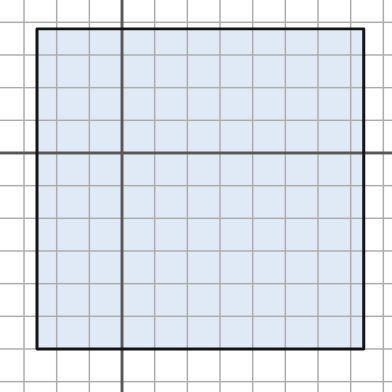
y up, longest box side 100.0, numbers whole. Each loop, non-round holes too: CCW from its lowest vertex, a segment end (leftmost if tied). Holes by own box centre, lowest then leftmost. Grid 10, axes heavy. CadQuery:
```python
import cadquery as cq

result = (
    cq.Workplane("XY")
    .moveTo(-26.0, -60.0)
    .lineTo(74.0, -60.0)
    .lineTo(74.0, 38.0)
    .lineTo(-26.0, 38.0)
    .close()
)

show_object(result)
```